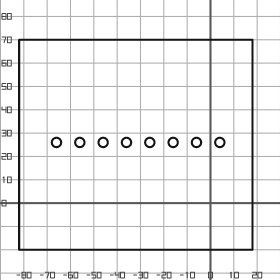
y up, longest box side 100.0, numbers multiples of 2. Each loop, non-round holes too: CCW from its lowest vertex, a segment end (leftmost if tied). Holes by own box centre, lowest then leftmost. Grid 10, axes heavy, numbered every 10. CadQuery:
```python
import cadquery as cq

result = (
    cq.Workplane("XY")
    .moveTo(-82.0, -20.0)
    .lineTo(18.0, -20.0)
    .lineTo(18.0, 70.0)
    .lineTo(-82.0, 70.0)
    .close()
    .moveTo(-66.0, 26.0)
    .circle(2.0)
    .moveTo(-56.0, 26.0)
    .circle(2.0)
    .moveTo(-46.0, 26.0)
    .circle(2.0)
    .moveTo(-36.0, 26.0)
    .circle(2.0)
    .moveTo(-26.0, 26.0)
    .circle(2.0)
    .moveTo(-16.0, 26.0)
    .circle(2.0)
    .moveTo(-6.0, 26.0)
    .circle(2.0)
    .moveTo(4.0, 26.0)
    .circle(2.0)
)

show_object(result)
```